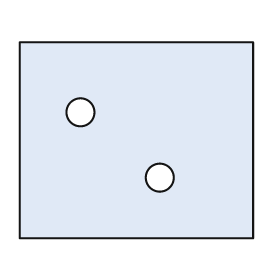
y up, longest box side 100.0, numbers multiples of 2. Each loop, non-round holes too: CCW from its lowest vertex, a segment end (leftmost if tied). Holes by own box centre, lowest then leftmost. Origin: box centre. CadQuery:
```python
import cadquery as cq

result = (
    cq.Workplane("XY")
    .moveTo(-50.0, -42.0)
    .lineTo(50.0, -42.0)
    .lineTo(50.0, 42.0)
    .lineTo(-50.0, 42.0)
    .close()
    .moveTo(10.0, -16.0)
    .circle(6.0)
    .moveTo(-24.0, 12.0)
    .circle(6.0)
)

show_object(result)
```